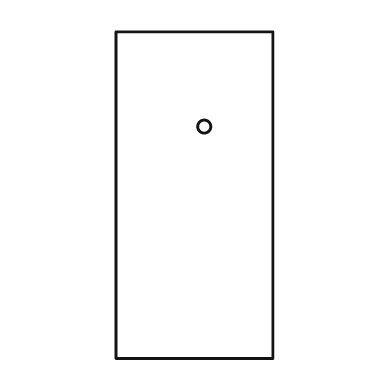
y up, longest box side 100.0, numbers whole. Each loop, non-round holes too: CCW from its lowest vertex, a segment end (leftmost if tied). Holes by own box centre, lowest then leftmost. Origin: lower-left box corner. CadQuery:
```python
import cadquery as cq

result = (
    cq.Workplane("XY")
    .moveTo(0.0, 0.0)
    .lineTo(48.0, 0.0)
    .lineTo(48.0, 100.0)
    .lineTo(0.0, 100.0)
    .close()
    .moveTo(27.0, 71.0)
    .circle(2.0)
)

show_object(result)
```